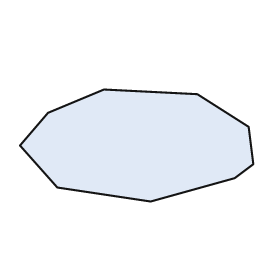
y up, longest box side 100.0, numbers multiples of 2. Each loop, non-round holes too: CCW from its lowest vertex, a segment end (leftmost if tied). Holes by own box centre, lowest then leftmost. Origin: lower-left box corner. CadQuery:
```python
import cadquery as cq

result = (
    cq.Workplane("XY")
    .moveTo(56.0, 0.0)
    .lineTo(92.0, 10.0)
    .lineTo(100.0, 16.0)
    .lineTo(98.0, 32.0)
    .lineTo(76.0, 46.0)
    .lineTo(36.0, 48.0)
    .lineTo(12.0, 38.0)
    .lineTo(0.0, 24.0)
    .lineTo(16.0, 6.0)
    .close()
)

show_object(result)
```